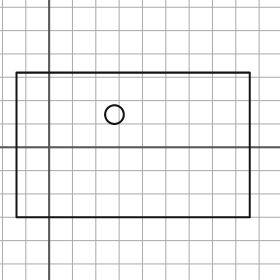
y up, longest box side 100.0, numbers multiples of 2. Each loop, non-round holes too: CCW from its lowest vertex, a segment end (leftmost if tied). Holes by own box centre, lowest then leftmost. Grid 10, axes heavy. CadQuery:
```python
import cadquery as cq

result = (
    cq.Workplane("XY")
    .moveTo(-14.0, -30.0)
    .lineTo(86.0, -30.0)
    .lineTo(86.0, 32.0)
    .lineTo(-14.0, 32.0)
    .close()
    .moveTo(28.0, 14.0)
    .circle(4.0)
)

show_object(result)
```